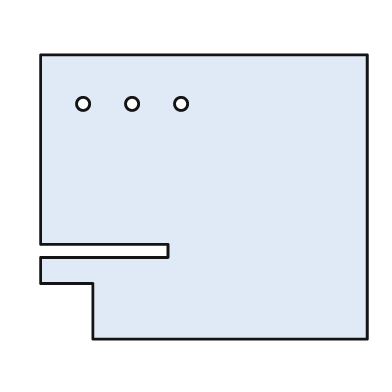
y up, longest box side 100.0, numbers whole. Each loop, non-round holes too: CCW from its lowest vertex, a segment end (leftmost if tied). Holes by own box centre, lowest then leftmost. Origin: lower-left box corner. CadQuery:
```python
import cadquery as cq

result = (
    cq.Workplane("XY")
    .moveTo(16.0, 0.0)
    .lineTo(100.0, 0.0)
    .lineTo(100.0, 87.0)
    .lineTo(0.0, 87.0)
    .lineTo(0.0, 29.0)
    .lineTo(39.0, 29.0)
    .lineTo(39.0, 25.0)
    .lineTo(0.0, 25.0)
    .lineTo(0.0, 17.0)
    .lineTo(16.0, 17.0)
    .close()
    .moveTo(13.0, 72.0)
    .circle(2.0)
    .moveTo(28.0, 72.0)
    .circle(2.0)
    .moveTo(43.0, 72.0)
    .circle(2.0)
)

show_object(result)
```